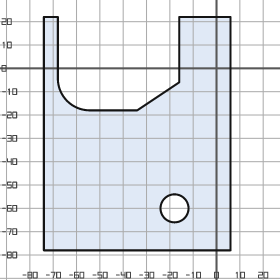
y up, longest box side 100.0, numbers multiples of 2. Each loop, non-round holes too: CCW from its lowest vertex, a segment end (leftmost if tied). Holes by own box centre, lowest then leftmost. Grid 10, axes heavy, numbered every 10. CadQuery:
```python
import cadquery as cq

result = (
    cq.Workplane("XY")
    .moveTo(-74.0, -78.0)
    .lineTo(6.0, -78.0)
    .lineTo(6.0, 22.0)
    .lineTo(-16.0, 22.0)
    .lineTo(-16.0, -6.0)
    .lineTo(-34.0, -18.0)
    .lineTo(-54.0, -18.0)
    .threePointArc((-64.0, -14.0), (-68.0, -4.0))
    .lineTo(-68.0, 22.0)
    .lineTo(-74.0, 22.0)
    .close()
    .moveTo(-18.0, -60.0)
    .circle(6.0)
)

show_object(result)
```